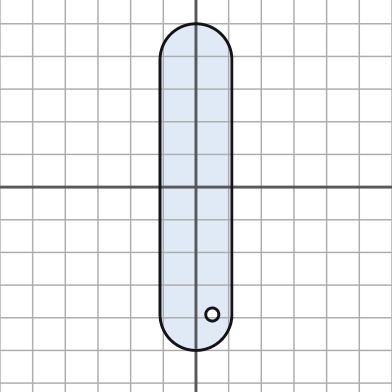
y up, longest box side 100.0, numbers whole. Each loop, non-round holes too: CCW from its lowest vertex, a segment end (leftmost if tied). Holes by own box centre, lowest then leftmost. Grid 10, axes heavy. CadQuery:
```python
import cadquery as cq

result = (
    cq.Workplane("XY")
    .moveTo(-11.0, -39.0)
    .threePointArc((0.0, -50.0), (11.0, -39.0))
    .lineTo(11.0, 39.0)
    .threePointArc((0.0, 50.0), (-11.0, 39.0))
    .close()
    .moveTo(5.0, -39.0)
    .circle(2.0)
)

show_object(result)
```